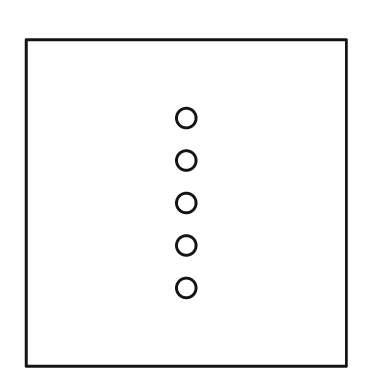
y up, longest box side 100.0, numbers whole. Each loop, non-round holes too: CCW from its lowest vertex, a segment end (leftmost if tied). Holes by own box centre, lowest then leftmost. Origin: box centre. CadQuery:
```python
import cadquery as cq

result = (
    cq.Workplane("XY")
    .moveTo(-49.0, -50.0)
    .lineTo(49.0, -50.0)
    .lineTo(49.0, 50.0)
    .lineTo(-49.0, 50.0)
    .close()
    .moveTo(0.0, -26.0)
    .circle(3.0)
    .moveTo(0.0, -13.0)
    .circle(3.0)
    .moveTo(0.0, 0.0)
    .circle(3.0)
    .moveTo(0.0, 13.0)
    .circle(3.0)
    .moveTo(0.0, 26.0)
    .circle(3.0)
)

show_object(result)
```